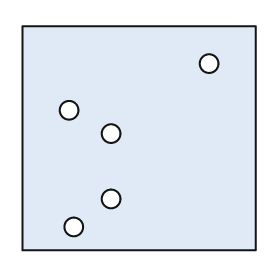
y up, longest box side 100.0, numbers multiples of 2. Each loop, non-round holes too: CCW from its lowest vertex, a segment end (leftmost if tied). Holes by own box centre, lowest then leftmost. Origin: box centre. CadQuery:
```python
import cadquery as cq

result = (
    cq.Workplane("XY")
    .moveTo(-50.0, -48.0)
    .lineTo(50.0, -48.0)
    .lineTo(50.0, 48.0)
    .lineTo(-50.0, 48.0)
    .close()
    .moveTo(-28.0, -38.0)
    .circle(4.0)
    .moveTo(-12.0, -26.0)
    .circle(4.0)
    .moveTo(-12.0, 2.0)
    .circle(4.0)
    .moveTo(-30.0, 12.0)
    .circle(4.0)
    .moveTo(30.0, 32.0)
    .circle(4.0)
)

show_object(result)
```